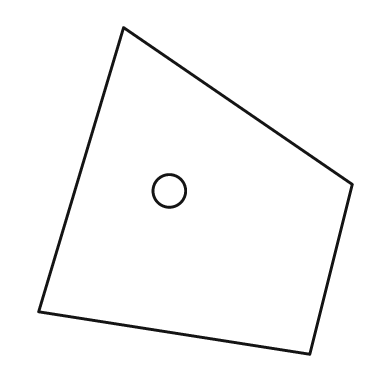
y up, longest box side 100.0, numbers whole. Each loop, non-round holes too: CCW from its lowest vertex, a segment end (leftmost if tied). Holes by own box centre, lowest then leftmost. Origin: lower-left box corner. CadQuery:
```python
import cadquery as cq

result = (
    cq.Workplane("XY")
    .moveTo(83.0, 0.0)
    .lineTo(96.0, 52.0)
    .lineTo(26.0, 100.0)
    .lineTo(0.0, 13.0)
    .close()
    .moveTo(40.0, 50.0)
    .circle(5.0)
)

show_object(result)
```